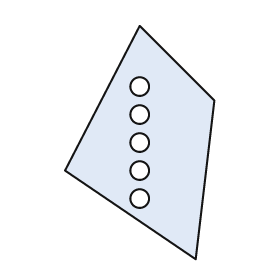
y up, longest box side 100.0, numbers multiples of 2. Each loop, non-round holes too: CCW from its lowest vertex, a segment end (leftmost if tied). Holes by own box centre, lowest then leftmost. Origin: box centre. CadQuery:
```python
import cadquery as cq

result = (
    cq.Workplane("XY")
    .moveTo(24.0, -50.0)
    .lineTo(32.0, 18.0)
    .lineTo(0.0, 50.0)
    .lineTo(-32.0, -12.0)
    .close()
    .moveTo(0.0, -24.0)
    .circle(4.0)
    .moveTo(0.0, -12.0)
    .circle(4.0)
    .moveTo(0.0, 0.0)
    .circle(4.0)
    .moveTo(0.0, 12.0)
    .circle(4.0)
    .moveTo(0.0, 24.0)
    .circle(4.0)
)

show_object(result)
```